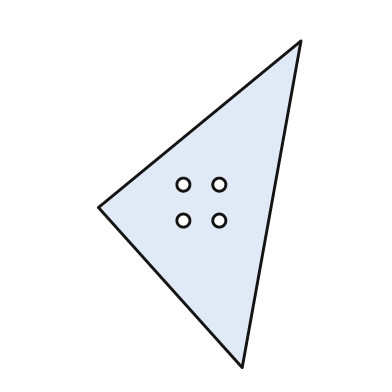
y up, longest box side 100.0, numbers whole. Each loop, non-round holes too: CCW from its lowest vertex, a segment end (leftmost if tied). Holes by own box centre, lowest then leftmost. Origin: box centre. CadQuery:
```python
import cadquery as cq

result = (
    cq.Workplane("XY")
    .moveTo(13.0, -50.0)
    .lineTo(31.0, 50.0)
    .lineTo(-31.0, -1.0)
    .close()
    .moveTo(-5.0, -5.0)
    .circle(2.0)
    .moveTo(6.0, -5.0)
    .circle(2.0)
    .moveTo(-5.0, 6.0)
    .circle(2.0)
    .moveTo(6.0, 6.0)
    .circle(2.0)
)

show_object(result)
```